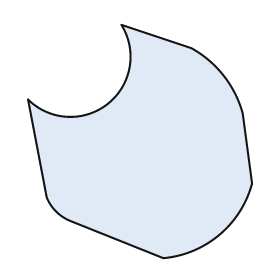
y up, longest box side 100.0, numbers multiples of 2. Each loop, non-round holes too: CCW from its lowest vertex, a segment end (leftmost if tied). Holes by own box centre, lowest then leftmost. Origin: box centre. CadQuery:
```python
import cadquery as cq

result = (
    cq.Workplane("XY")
    .moveTo(10.0, -50.0)
    .threePointArc((34.0, -40.0), (48.0, -18.0))
    .lineTo(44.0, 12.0)
    .threePointArc((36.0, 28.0), (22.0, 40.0))
    .lineTo(-8.0, 50.0)
    .threePointArc((-14.0, 16.0), (-48.0, 18.0))
    .lineTo(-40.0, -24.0)
    .threePointArc((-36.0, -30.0), (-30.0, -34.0))
    .close()
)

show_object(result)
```